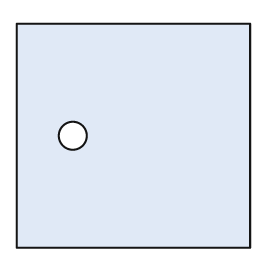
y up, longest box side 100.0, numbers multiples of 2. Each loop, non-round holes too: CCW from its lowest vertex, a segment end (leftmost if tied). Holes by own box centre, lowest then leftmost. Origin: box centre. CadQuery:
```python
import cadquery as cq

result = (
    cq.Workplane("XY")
    .moveTo(-50.0, -48.0)
    .lineTo(50.0, -48.0)
    .lineTo(50.0, 48.0)
    .lineTo(-50.0, 48.0)
    .close()
    .moveTo(-26.0, 0.0)
    .circle(6.0)
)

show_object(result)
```